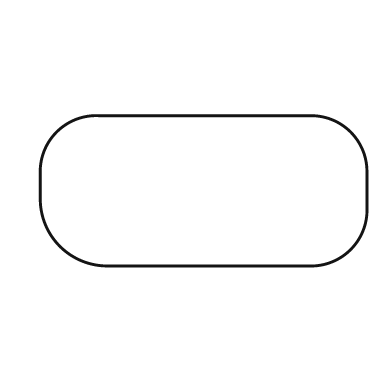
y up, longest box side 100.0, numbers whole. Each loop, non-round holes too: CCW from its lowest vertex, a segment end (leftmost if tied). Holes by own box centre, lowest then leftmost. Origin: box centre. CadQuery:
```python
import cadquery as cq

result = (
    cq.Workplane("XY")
    .moveTo(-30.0, -23.0)
    .lineTo(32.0, -23.0)
    .threePointArc((45.0, -18.0), (50.0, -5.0))
    .lineTo(50.0, 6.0)
    .threePointArc((45.0, 18.0), (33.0, 23.0))
    .lineTo(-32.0, 23.0)
    .threePointArc((-45.0, 18.0), (-50.0, 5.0))
    .lineTo(-50.0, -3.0)
    .threePointArc((-44.0, -17.0), (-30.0, -23.0))
    .close()
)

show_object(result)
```